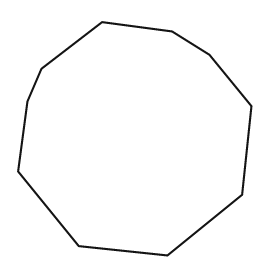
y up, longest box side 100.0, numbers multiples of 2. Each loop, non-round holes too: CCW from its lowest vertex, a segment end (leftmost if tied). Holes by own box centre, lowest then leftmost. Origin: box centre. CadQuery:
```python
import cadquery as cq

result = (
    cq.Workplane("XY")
    .moveTo(14.0, -50.0)
    .lineTo(46.0, -24.0)
    .lineTo(50.0, 14.0)
    .lineTo(32.0, 36.0)
    .lineTo(16.0, 46.0)
    .lineTo(-14.0, 50.0)
    .lineTo(-40.0, 30.0)
    .lineTo(-46.0, 16.0)
    .lineTo(-50.0, -14.0)
    .lineTo(-24.0, -46.0)
    .close()
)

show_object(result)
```